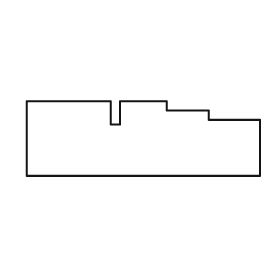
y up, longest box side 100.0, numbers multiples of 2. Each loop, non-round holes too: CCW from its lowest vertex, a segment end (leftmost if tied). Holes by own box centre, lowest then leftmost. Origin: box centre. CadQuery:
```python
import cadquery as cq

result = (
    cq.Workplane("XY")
    .moveTo(-50.0, -16.0)
    .lineTo(50.0, -16.0)
    .lineTo(50.0, 8.0)
    .lineTo(28.0, 8.0)
    .lineTo(28.0, 12.0)
    .lineTo(10.0, 12.0)
    .lineTo(10.0, 16.0)
    .lineTo(-10.0, 16.0)
    .lineTo(-10.0, 6.0)
    .lineTo(-14.0, 6.0)
    .lineTo(-14.0, 16.0)
    .lineTo(-50.0, 16.0)
    .close()
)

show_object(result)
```